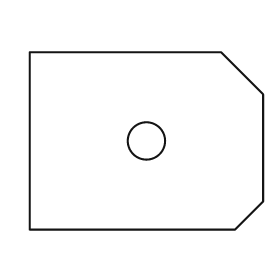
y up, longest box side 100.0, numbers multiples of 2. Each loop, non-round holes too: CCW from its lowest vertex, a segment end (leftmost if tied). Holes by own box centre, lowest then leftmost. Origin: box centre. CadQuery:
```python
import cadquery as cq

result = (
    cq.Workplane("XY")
    .moveTo(-50.0, -38.0)
    .lineTo(38.0, -38.0)
    .lineTo(50.0, -26.0)
    .lineTo(50.0, 20.0)
    .lineTo(32.0, 38.0)
    .lineTo(-50.0, 38.0)
    .close()
    .moveTo(0.0, 0.0)
    .circle(8.0)
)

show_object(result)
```